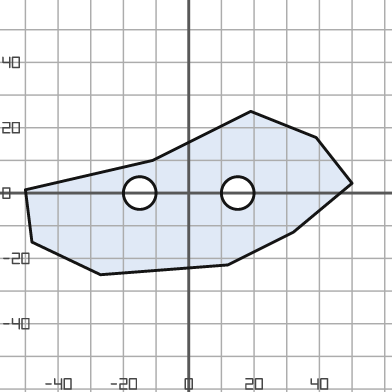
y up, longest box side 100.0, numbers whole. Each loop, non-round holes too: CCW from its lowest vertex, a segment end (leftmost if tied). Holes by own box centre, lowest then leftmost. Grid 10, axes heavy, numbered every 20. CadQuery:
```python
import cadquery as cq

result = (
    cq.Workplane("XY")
    .moveTo(-27.0, -25.0)
    .lineTo(12.0, -22.0)
    .lineTo(32.0, -12.0)
    .lineTo(50.0, 3.0)
    .lineTo(39.0, 17.0)
    .lineTo(19.0, 25.0)
    .lineTo(-11.0, 10.0)
    .lineTo(-50.0, 1.0)
    .lineTo(-48.0, -15.0)
    .close()
    .moveTo(-15.0, 0.0)
    .circle(5.0)
    .moveTo(15.0, 0.0)
    .circle(5.0)
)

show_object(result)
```